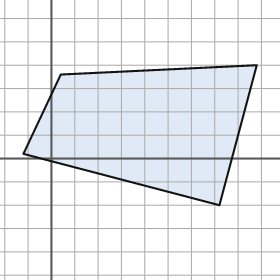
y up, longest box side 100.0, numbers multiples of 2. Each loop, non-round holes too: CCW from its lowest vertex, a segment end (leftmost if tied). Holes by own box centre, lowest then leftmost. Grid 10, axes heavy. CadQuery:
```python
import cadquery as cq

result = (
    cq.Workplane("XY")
    .moveTo(72.0, -20.0)
    .lineTo(88.0, 40.0)
    .lineTo(4.0, 36.0)
    .lineTo(-12.0, 2.0)
    .close()
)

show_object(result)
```